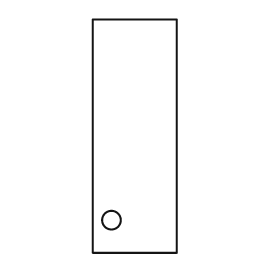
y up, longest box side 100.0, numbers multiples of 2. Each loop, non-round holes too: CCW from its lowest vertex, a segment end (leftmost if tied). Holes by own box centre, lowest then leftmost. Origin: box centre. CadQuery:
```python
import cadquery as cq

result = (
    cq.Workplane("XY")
    .moveTo(-18.0, -50.0)
    .lineTo(18.0, -50.0)
    .lineTo(18.0, 50.0)
    .lineTo(-18.0, 50.0)
    .close()
    .moveTo(-10.0, -36.0)
    .circle(4.0)
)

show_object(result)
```